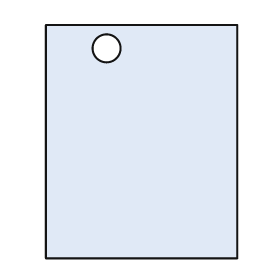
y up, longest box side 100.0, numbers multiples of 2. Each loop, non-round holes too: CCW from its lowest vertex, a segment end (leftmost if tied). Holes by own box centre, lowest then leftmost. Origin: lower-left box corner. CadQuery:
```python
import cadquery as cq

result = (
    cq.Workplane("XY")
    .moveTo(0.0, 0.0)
    .lineTo(82.0, 0.0)
    .lineTo(82.0, 100.0)
    .lineTo(0.0, 100.0)
    .close()
    .moveTo(26.0, 90.0)
    .circle(6.0)
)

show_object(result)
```